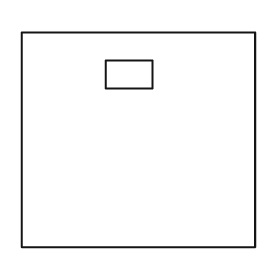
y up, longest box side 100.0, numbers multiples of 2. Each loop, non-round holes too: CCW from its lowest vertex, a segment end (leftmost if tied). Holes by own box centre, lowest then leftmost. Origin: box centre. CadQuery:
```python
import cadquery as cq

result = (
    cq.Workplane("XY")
    .moveTo(-50.0, -46.0)
    .lineTo(50.0, -46.0)
    .lineTo(50.0, 46.0)
    .lineTo(-50.0, 46.0)
    .close()
    .moveTo(-14.0, 22.0)
    .lineTo(6.0, 22.0)
    .lineTo(6.0, 34.0)
    .lineTo(-14.0, 34.0)
    .close()
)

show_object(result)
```